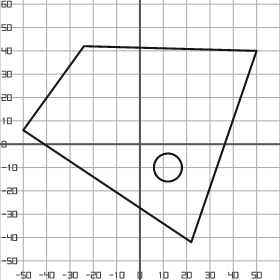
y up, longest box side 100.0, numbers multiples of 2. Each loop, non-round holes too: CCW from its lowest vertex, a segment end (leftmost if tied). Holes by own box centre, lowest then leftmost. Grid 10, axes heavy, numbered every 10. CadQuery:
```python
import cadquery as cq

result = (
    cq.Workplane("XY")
    .moveTo(22.0, -42.0)
    .lineTo(50.0, 40.0)
    .lineTo(-24.0, 42.0)
    .lineTo(-50.0, 6.0)
    .close()
    .moveTo(12.0, -10.0)
    .circle(6.0)
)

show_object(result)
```